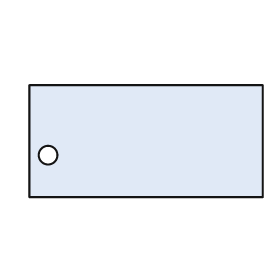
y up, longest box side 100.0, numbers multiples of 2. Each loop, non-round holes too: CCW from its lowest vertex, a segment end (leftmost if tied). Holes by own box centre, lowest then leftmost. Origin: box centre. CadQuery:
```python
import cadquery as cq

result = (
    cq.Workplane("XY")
    .moveTo(-50.0, -24.0)
    .lineTo(50.0, -24.0)
    .lineTo(50.0, 24.0)
    .lineTo(-50.0, 24.0)
    .close()
    .moveTo(-42.0, -6.0)
    .circle(4.0)
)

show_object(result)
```